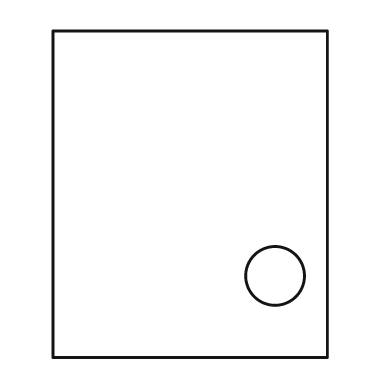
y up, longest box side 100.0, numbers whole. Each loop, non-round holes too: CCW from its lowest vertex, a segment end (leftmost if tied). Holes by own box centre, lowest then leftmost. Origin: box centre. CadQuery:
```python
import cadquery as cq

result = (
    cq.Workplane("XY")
    .moveTo(-42.0, -50.0)
    .lineTo(42.0, -50.0)
    .lineTo(42.0, 50.0)
    .lineTo(-42.0, 50.0)
    .close()
    .moveTo(26.0, -25.0)
    .circle(9.0)
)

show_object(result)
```